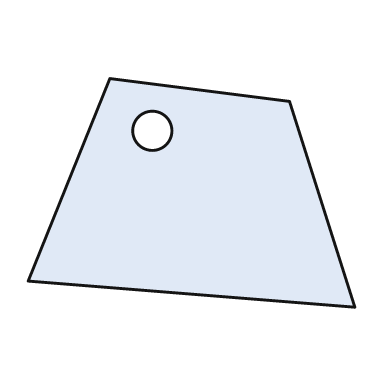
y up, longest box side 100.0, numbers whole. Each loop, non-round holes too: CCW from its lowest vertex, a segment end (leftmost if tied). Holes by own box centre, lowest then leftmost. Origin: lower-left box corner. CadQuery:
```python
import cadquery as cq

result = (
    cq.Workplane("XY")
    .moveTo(100.0, 0.0)
    .lineTo(80.0, 63.0)
    .lineTo(25.0, 70.0)
    .lineTo(0.0, 8.0)
    .close()
    .moveTo(38.0, 54.0)
    .circle(6.0)
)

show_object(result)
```